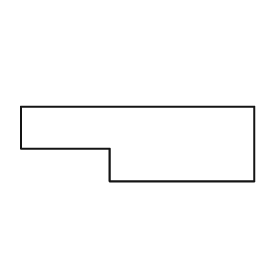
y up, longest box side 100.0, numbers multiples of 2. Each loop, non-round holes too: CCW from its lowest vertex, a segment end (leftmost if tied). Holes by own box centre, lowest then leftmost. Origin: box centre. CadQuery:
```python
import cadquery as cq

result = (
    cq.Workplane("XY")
    .moveTo(-12.0, -16.0)
    .lineTo(50.0, -16.0)
    .lineTo(50.0, 16.0)
    .lineTo(-50.0, 16.0)
    .lineTo(-50.0, -2.0)
    .lineTo(-12.0, -2.0)
    .close()
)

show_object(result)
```